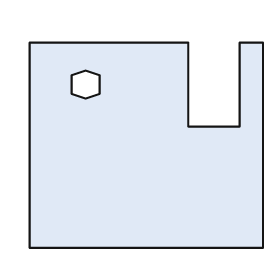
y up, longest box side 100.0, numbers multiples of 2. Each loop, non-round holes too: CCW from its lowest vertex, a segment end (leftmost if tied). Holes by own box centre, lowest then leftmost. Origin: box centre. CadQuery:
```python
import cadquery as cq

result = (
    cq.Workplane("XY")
    .moveTo(-50.0, -44.0)
    .lineTo(50.0, -44.0)
    .lineTo(50.0, 44.0)
    .lineTo(40.0, 44.0)
    .lineTo(40.0, 8.0)
    .lineTo(18.0, 8.0)
    .lineTo(18.0, 44.0)
    .lineTo(-50.0, 44.0)
    .close()
    .moveTo(-26.0, 20.0)
    .lineTo(-20.0, 22.0)
    .lineTo(-20.0, 30.0)
    .lineTo(-26.0, 32.0)
    .lineTo(-32.0, 30.0)
    .lineTo(-32.0, 22.0)
    .close()
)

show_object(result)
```